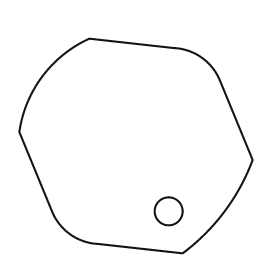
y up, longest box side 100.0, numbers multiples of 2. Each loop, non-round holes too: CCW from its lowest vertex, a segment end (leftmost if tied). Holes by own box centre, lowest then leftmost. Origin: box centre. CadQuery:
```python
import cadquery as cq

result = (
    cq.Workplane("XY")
    .moveTo(20.0, -46.0)
    .threePointArc((38.0, -28.0), (50.0, -6.0))
    .lineTo(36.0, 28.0)
    .threePointArc((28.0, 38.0), (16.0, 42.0))
    .lineTo(-20.0, 46.0)
    .threePointArc((-40.0, 30.0), (-50.0, 6.0))
    .lineTo(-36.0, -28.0)
    .threePointArc((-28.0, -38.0), (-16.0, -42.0))
    .close()
    .moveTo(14.0, -28.0)
    .circle(6.0)
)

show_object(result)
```